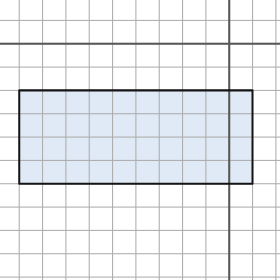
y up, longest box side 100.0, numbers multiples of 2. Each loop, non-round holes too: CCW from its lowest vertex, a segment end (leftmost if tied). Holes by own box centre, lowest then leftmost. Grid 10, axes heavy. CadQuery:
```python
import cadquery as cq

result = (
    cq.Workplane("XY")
    .moveTo(-90.0, -60.0)
    .lineTo(10.0, -60.0)
    .lineTo(10.0, -20.0)
    .lineTo(-90.0, -20.0)
    .close()
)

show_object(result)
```